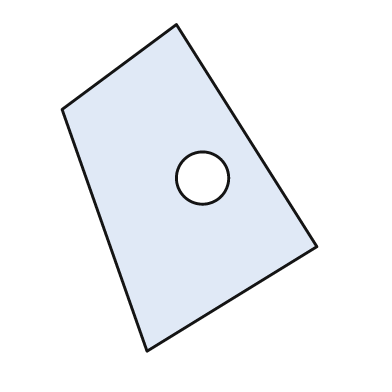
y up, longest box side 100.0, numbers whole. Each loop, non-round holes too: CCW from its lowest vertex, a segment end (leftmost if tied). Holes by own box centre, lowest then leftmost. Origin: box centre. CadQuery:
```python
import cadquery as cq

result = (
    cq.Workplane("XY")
    .moveTo(-13.0, -50.0)
    .lineTo(39.0, -18.0)
    .lineTo(-4.0, 50.0)
    .lineTo(-39.0, 24.0)
    .close()
    .moveTo(4.0, 3.0)
    .circle(8.0)
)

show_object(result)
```